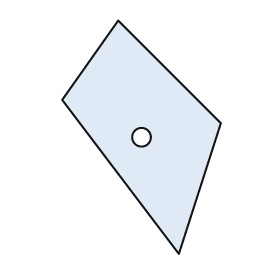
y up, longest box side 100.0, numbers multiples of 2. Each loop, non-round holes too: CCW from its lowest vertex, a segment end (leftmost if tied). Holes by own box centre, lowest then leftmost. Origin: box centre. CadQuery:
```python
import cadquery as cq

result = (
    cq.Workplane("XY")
    .moveTo(16.0, -50.0)
    .lineTo(34.0, 6.0)
    .lineTo(-10.0, 50.0)
    .lineTo(-34.0, 16.0)
    .close()
    .moveTo(0.0, 0.0)
    .circle(4.0)
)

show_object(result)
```